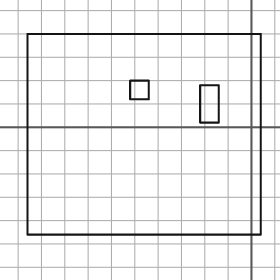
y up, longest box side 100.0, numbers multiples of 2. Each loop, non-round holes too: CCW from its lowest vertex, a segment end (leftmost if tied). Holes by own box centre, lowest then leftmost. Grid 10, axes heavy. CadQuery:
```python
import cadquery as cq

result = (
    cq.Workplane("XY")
    .moveTo(-96.0, -46.0)
    .lineTo(4.0, -46.0)
    .lineTo(4.0, 40.0)
    .lineTo(-96.0, 40.0)
    .close()
    .moveTo(-22.0, 2.0)
    .lineTo(-14.0, 2.0)
    .lineTo(-14.0, 18.0)
    .lineTo(-22.0, 18.0)
    .close()
    .moveTo(-52.0, 12.0)
    .lineTo(-44.0, 12.0)
    .lineTo(-44.0, 20.0)
    .lineTo(-52.0, 20.0)
    .close()
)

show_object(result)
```